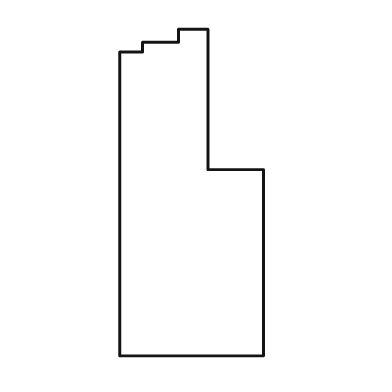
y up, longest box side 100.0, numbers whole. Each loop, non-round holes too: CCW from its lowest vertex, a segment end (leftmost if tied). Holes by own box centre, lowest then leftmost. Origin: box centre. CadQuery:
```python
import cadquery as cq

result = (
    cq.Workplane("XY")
    .moveTo(-22.0, -50.0)
    .lineTo(22.0, -50.0)
    .lineTo(22.0, 7.0)
    .lineTo(5.0, 7.0)
    .lineTo(5.0, 50.0)
    .lineTo(-4.0, 50.0)
    .lineTo(-4.0, 46.0)
    .lineTo(-15.0, 46.0)
    .lineTo(-15.0, 43.0)
    .lineTo(-22.0, 43.0)
    .close()
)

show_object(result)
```